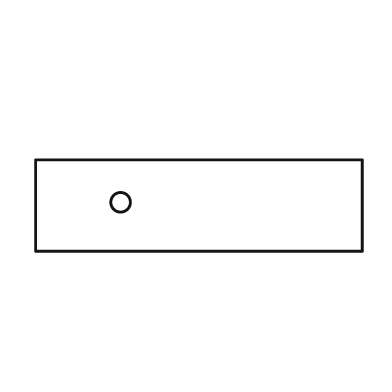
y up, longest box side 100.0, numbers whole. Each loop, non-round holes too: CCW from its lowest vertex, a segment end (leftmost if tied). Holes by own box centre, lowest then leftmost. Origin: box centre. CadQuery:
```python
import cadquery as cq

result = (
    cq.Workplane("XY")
    .moveTo(-50.0, -14.0)
    .lineTo(50.0, -14.0)
    .lineTo(50.0, 14.0)
    .lineTo(-50.0, 14.0)
    .close()
    .moveTo(-24.0, 1.0)
    .circle(3.0)
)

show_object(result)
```